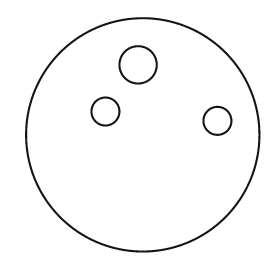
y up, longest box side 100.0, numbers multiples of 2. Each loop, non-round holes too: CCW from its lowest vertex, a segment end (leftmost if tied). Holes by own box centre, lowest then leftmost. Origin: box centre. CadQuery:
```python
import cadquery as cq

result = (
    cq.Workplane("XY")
    .moveTo(0.0, 0.0)
    .circle(50.0)
    .moveTo(32.0, 6.0)
    .circle(6.0)
    .moveTo(-16.0, 10.0)
    .circle(6.0)
    .moveTo(-2.0, 30.0)
    .circle(8.0)
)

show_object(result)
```